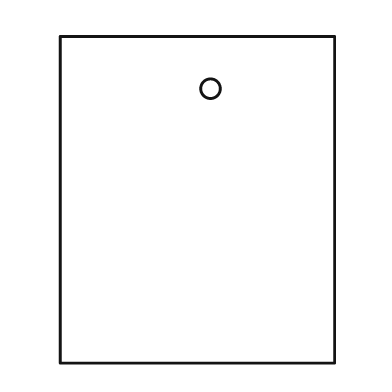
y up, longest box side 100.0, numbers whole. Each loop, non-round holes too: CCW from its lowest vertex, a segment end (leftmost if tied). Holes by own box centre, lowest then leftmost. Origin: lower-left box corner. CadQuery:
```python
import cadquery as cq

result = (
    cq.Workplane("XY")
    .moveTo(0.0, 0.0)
    .lineTo(84.0, 0.0)
    .lineTo(84.0, 100.0)
    .lineTo(0.0, 100.0)
    .close()
    .moveTo(46.0, 84.0)
    .circle(3.0)
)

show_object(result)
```